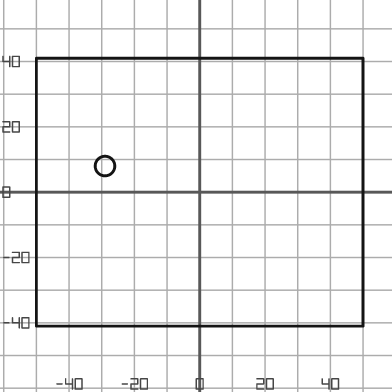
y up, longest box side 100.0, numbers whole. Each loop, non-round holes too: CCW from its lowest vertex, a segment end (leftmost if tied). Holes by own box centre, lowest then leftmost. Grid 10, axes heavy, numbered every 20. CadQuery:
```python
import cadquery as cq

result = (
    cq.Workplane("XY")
    .moveTo(-50.0, -41.0)
    .lineTo(50.0, -41.0)
    .lineTo(50.0, 41.0)
    .lineTo(-50.0, 41.0)
    .close()
    .moveTo(-29.0, 8.0)
    .circle(3.0)
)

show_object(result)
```